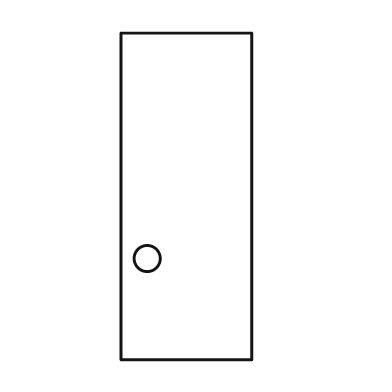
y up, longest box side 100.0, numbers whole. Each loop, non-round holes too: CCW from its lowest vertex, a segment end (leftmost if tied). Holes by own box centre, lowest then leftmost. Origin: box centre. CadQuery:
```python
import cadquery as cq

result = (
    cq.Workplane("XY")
    .moveTo(-20.0, -50.0)
    .lineTo(20.0, -50.0)
    .lineTo(20.0, 50.0)
    .lineTo(-20.0, 50.0)
    .close()
    .moveTo(-12.0, -19.0)
    .circle(4.0)
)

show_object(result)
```